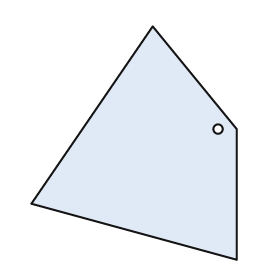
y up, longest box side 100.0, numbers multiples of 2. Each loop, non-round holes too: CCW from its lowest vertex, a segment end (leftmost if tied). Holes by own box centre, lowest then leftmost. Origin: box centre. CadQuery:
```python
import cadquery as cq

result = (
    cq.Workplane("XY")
    .moveTo(44.0, -50.0)
    .lineTo(44.0, 6.0)
    .lineTo(8.0, 50.0)
    .lineTo(-44.0, -26.0)
    .close()
    .moveTo(36.0, 6.0)
    .circle(2.0)
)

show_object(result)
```